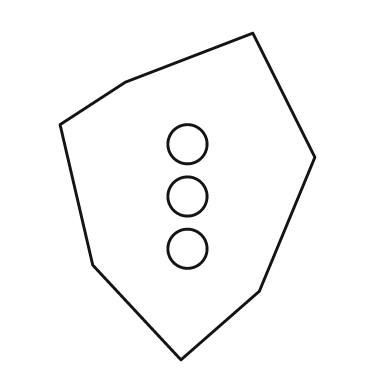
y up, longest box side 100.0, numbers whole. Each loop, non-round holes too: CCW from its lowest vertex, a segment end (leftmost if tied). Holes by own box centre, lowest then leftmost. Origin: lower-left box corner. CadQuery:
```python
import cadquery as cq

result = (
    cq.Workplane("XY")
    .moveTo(37.0, 0.0)
    .lineTo(61.0, 21.0)
    .lineTo(78.0, 62.0)
    .lineTo(59.0, 100.0)
    .lineTo(20.0, 85.0)
    .lineTo(0.0, 72.0)
    .lineTo(10.0, 29.0)
    .close()
    .moveTo(39.0, 34.0)
    .circle(6.0)
    .moveTo(39.0, 50.0)
    .circle(6.0)
    .moveTo(39.0, 66.0)
    .circle(6.0)
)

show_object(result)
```